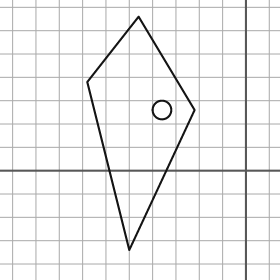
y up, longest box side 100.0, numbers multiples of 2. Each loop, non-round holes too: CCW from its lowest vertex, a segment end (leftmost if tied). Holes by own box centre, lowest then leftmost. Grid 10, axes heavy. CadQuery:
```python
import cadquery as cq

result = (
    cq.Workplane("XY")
    .moveTo(-50.0, -34.0)
    .lineTo(-22.0, 26.0)
    .lineTo(-46.0, 66.0)
    .lineTo(-68.0, 38.0)
    .close()
    .moveTo(-36.0, 26.0)
    .circle(4.0)
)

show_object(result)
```